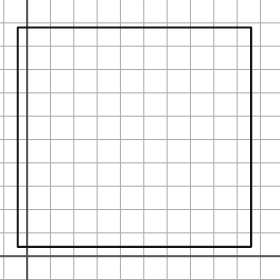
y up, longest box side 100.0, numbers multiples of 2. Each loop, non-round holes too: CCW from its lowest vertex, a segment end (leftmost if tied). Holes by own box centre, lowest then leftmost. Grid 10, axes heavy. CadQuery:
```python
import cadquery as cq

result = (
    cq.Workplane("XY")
    .moveTo(-4.0, 4.0)
    .lineTo(96.0, 4.0)
    .lineTo(96.0, 98.0)
    .lineTo(-4.0, 98.0)
    .close()
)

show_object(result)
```